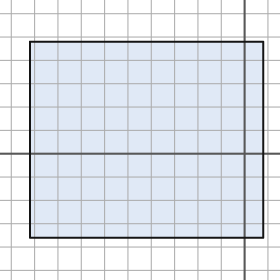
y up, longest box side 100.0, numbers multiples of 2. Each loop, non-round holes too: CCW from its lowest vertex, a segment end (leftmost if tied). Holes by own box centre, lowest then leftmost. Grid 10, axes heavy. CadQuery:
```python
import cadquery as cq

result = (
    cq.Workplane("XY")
    .moveTo(-92.0, -36.0)
    .lineTo(8.0, -36.0)
    .lineTo(8.0, 48.0)
    .lineTo(-92.0, 48.0)
    .close()
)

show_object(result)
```